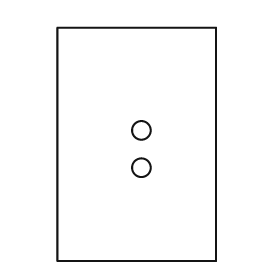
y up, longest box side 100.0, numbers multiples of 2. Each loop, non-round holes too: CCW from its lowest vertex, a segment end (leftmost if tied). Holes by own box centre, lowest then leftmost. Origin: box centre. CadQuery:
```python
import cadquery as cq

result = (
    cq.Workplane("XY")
    .moveTo(-34.0, -50.0)
    .lineTo(34.0, -50.0)
    .lineTo(34.0, 50.0)
    .lineTo(-34.0, 50.0)
    .close()
    .moveTo(2.0, -10.0)
    .circle(4.0)
    .moveTo(2.0, 6.0)
    .circle(4.0)
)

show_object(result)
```